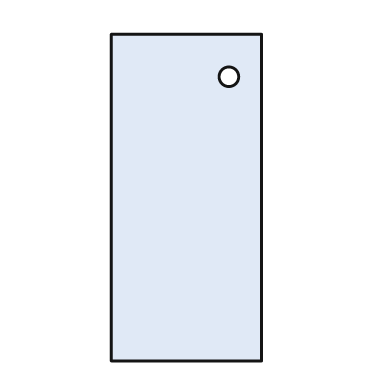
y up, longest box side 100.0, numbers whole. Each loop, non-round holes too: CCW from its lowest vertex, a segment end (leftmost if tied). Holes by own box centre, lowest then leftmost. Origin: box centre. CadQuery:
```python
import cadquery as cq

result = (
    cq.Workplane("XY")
    .moveTo(-23.0, -50.0)
    .lineTo(23.0, -50.0)
    .lineTo(23.0, 50.0)
    .lineTo(-23.0, 50.0)
    .close()
    .moveTo(13.0, 37.0)
    .circle(3.0)
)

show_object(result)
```